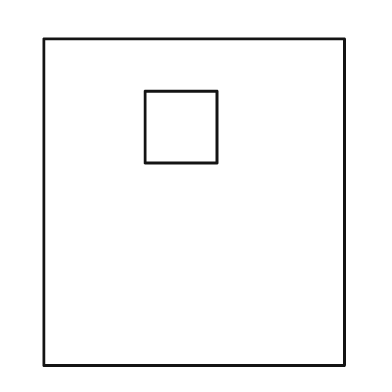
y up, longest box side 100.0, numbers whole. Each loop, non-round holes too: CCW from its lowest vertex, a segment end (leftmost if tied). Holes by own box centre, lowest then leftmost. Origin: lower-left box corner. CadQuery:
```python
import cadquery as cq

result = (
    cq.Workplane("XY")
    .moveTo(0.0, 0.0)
    .lineTo(92.0, 0.0)
    .lineTo(92.0, 100.0)
    .lineTo(0.0, 100.0)
    .close()
    .moveTo(31.0, 62.0)
    .lineTo(53.0, 62.0)
    .lineTo(53.0, 84.0)
    .lineTo(31.0, 84.0)
    .close()
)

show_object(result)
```